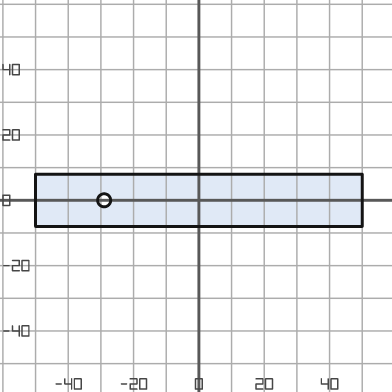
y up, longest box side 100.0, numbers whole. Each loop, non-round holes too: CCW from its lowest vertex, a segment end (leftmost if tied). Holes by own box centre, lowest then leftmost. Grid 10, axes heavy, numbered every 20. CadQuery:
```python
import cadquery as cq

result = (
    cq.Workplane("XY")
    .moveTo(-50.0, -8.0)
    .lineTo(50.0, -8.0)
    .lineTo(50.0, 8.0)
    .lineTo(-50.0, 8.0)
    .close()
    .moveTo(-29.0, 0.0)
    .circle(2.0)
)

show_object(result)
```